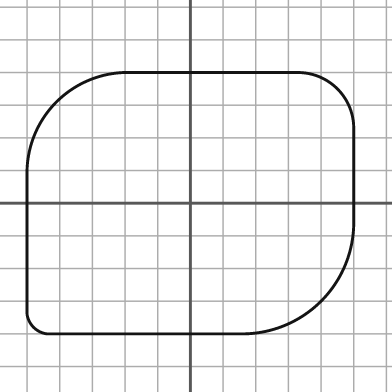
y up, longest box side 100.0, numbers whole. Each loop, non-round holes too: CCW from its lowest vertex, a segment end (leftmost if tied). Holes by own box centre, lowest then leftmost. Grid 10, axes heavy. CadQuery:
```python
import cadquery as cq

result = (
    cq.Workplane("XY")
    .moveTo(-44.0, -40.0)
    .lineTo(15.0, -40.0)
    .threePointArc((40.0, -30.0), (50.0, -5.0))
    .lineTo(50.0, 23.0)
    .threePointArc((45.0, 35.0), (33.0, 40.0))
    .lineTo(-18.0, 40.0)
    .threePointArc((-41.0, 31.0), (-50.0, 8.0))
    .lineTo(-50.0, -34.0)
    .threePointArc((-48.0, -38.0), (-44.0, -40.0))
    .close()
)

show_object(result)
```